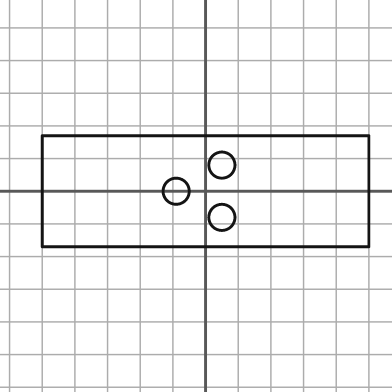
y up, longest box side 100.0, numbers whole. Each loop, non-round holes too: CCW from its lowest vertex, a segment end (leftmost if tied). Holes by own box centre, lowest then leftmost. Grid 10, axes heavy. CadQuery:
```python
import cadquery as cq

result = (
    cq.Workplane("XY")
    .moveTo(-50.0, -17.0)
    .lineTo(50.0, -17.0)
    .lineTo(50.0, 17.0)
    .lineTo(-50.0, 17.0)
    .close()
    .moveTo(5.0, -8.0)
    .circle(4.0)
    .moveTo(-9.0, 0.0)
    .circle(4.0)
    .moveTo(5.0, 8.0)
    .circle(4.0)
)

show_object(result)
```